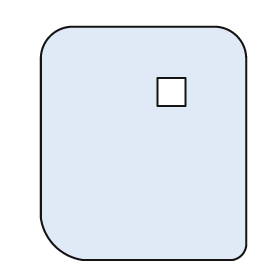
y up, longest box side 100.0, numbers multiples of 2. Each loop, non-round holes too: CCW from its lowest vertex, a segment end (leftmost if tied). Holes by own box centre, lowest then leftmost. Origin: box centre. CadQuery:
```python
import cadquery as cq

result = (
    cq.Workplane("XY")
    .moveTo(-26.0, -50.0)
    .lineTo(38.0, -50.0)
    .threePointArc((42.0, -48.0), (44.0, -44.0))
    .lineTo(44.0, 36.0)
    .threePointArc((40.0, 46.0), (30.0, 50.0))
    .lineTo(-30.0, 50.0)
    .threePointArc((-40.0, 46.0), (-44.0, 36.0))
    .lineTo(-44.0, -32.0)
    .threePointArc((-38.0, -44.0), (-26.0, -50.0))
    .close()
    .moveTo(6.0, 16.0)
    .lineTo(18.0, 16.0)
    .lineTo(18.0, 28.0)
    .lineTo(6.0, 28.0)
    .close()
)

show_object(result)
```